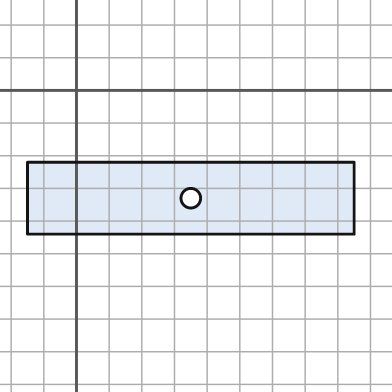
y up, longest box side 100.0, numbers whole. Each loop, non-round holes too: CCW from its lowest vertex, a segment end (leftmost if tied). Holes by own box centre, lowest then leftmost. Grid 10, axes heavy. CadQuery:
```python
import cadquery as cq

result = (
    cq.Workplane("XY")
    .moveTo(-15.0, -44.0)
    .lineTo(85.0, -44.0)
    .lineTo(85.0, -22.0)
    .lineTo(-15.0, -22.0)
    .close()
    .moveTo(35.0, -33.0)
    .circle(3.0)
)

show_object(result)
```